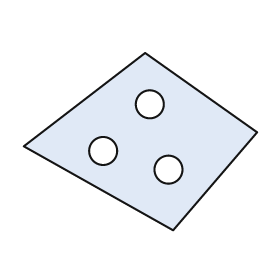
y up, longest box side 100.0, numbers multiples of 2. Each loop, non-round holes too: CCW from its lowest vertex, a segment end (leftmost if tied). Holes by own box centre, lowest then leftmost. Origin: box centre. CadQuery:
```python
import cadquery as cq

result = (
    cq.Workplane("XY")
    .moveTo(14.0, -38.0)
    .lineTo(50.0, 4.0)
    .lineTo(2.0, 38.0)
    .lineTo(-50.0, -2.0)
    .close()
    .moveTo(12.0, -12.0)
    .circle(6.0)
    .moveTo(-16.0, -4.0)
    .circle(6.0)
    .moveTo(4.0, 16.0)
    .circle(6.0)
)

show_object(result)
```